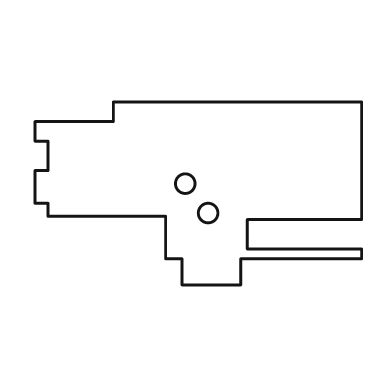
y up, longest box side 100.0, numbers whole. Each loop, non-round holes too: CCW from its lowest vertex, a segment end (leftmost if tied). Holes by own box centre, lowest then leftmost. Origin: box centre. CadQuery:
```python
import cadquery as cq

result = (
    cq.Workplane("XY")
    .moveTo(-5.0, -28.0)
    .lineTo(13.0, -28.0)
    .lineTo(13.0, -20.0)
    .lineTo(50.0, -20.0)
    .lineTo(50.0, -17.0)
    .lineTo(15.0, -17.0)
    .lineTo(15.0, -8.0)
    .lineTo(50.0, -8.0)
    .lineTo(50.0, 28.0)
    .lineTo(-26.0, 28.0)
    .lineTo(-26.0, 22.0)
    .lineTo(-50.0, 22.0)
    .lineTo(-50.0, 16.0)
    .lineTo(-46.0, 16.0)
    .lineTo(-46.0, 7.0)
    .lineTo(-50.0, 7.0)
    .lineTo(-50.0, -3.0)
    .lineTo(-46.0, -3.0)
    .lineTo(-46.0, -7.0)
    .lineTo(-10.0, -7.0)
    .lineTo(-10.0, -20.0)
    .lineTo(-5.0, -20.0)
    .close()
    .moveTo(3.0, -6.0)
    .circle(3.0)
    .moveTo(-4.0, 3.0)
    .circle(3.0)
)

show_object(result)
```